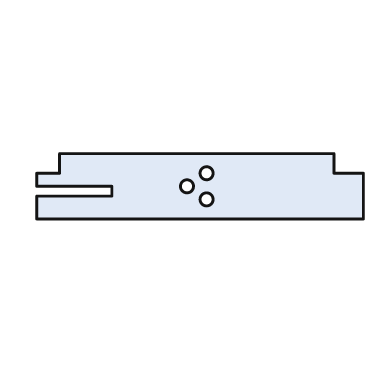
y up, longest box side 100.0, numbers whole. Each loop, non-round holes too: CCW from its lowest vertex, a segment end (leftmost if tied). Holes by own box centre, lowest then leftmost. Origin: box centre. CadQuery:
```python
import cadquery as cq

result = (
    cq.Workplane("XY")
    .moveTo(-50.0, -10.0)
    .lineTo(50.0, -10.0)
    .lineTo(50.0, 4.0)
    .lineTo(41.0, 4.0)
    .lineTo(41.0, 10.0)
    .lineTo(-43.0, 10.0)
    .lineTo(-43.0, 4.0)
    .lineTo(-50.0, 4.0)
    .lineTo(-50.0, 0.0)
    .lineTo(-27.0, 0.0)
    .lineTo(-27.0, -3.0)
    .lineTo(-50.0, -3.0)
    .close()
    .moveTo(2.0, -4.0)
    .circle(2.0)
    .moveTo(-4.0, 0.0)
    .circle(2.0)
    .moveTo(2.0, 4.0)
    .circle(2.0)
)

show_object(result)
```